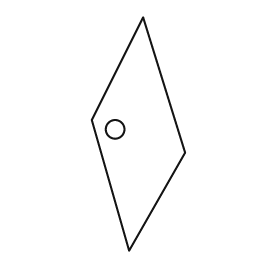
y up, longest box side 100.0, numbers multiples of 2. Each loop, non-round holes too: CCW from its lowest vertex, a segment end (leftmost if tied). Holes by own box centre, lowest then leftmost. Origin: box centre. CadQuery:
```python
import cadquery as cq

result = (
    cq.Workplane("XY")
    .moveTo(-4.0, -50.0)
    .lineTo(20.0, -8.0)
    .lineTo(2.0, 50.0)
    .lineTo(-20.0, 6.0)
    .close()
    .moveTo(-10.0, 2.0)
    .circle(4.0)
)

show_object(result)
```